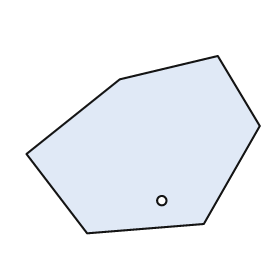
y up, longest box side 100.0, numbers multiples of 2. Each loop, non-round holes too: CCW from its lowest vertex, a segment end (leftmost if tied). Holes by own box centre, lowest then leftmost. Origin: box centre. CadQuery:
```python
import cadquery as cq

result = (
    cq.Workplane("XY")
    .moveTo(-24.0, -38.0)
    .lineTo(26.0, -34.0)
    .lineTo(50.0, 8.0)
    .lineTo(32.0, 38.0)
    .lineTo(-10.0, 28.0)
    .lineTo(-50.0, -4.0)
    .close()
    .moveTo(8.0, -24.0)
    .circle(2.0)
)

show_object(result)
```